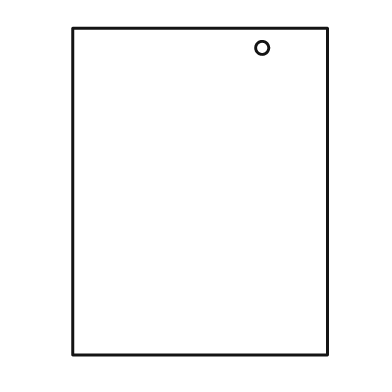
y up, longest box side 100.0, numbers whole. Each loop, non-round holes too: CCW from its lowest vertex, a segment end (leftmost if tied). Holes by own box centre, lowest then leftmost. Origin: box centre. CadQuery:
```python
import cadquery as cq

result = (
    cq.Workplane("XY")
    .moveTo(-39.0, -50.0)
    .lineTo(39.0, -50.0)
    .lineTo(39.0, 50.0)
    .lineTo(-39.0, 50.0)
    .close()
    .moveTo(19.0, 44.0)
    .circle(2.0)
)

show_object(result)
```